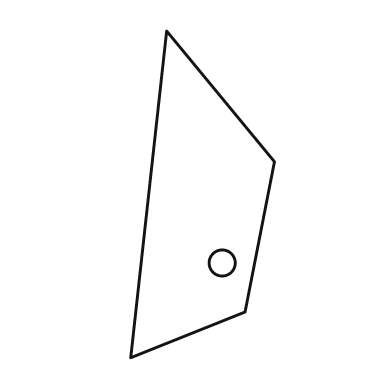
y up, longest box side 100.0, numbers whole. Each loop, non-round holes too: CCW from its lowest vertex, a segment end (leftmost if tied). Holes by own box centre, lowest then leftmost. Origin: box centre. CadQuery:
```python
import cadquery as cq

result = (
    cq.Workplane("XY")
    .moveTo(-22.0, -50.0)
    .lineTo(13.0, -36.0)
    .lineTo(22.0, 10.0)
    .lineTo(-11.0, 50.0)
    .close()
    .moveTo(6.0, -21.0)
    .circle(4.0)
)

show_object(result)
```